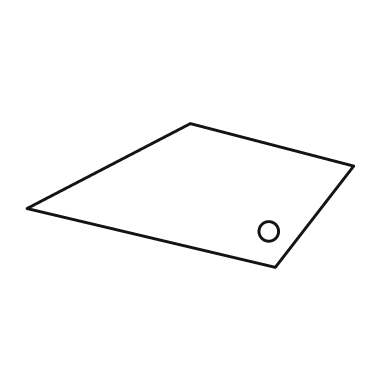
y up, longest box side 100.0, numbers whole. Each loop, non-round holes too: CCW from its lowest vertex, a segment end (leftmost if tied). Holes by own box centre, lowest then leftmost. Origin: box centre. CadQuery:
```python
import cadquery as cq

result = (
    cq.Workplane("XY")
    .moveTo(26.0, -22.0)
    .lineTo(50.0, 9.0)
    .lineTo(0.0, 22.0)
    .lineTo(-50.0, -4.0)
    .close()
    .moveTo(24.0, -11.0)
    .circle(3.0)
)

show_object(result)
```